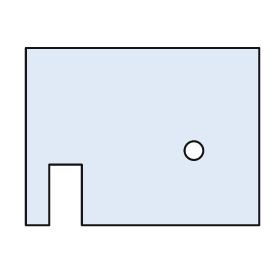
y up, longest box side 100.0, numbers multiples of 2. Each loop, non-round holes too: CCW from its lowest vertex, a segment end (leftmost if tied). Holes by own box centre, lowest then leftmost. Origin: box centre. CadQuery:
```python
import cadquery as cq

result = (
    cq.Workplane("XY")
    .moveTo(-50.0, -38.0)
    .lineTo(-40.0, -38.0)
    .lineTo(-40.0, -12.0)
    .lineTo(-26.0, -12.0)
    .lineTo(-26.0, -38.0)
    .lineTo(50.0, -38.0)
    .lineTo(50.0, 38.0)
    .lineTo(-50.0, 38.0)
    .close()
    .moveTo(22.0, -6.0)
    .circle(4.0)
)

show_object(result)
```